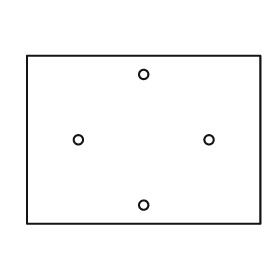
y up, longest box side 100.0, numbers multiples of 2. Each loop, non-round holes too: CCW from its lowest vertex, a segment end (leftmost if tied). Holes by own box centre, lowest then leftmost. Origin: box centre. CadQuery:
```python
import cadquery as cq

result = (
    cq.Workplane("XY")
    .moveTo(-50.0, -36.0)
    .lineTo(50.0, -36.0)
    .lineTo(50.0, 36.0)
    .lineTo(-50.0, 36.0)
    .close()
    .moveTo(0.0, -28.0)
    .circle(2.0)
    .moveTo(-28.0, 0.0)
    .circle(2.0)
    .moveTo(28.0, 0.0)
    .circle(2.0)
    .moveTo(0.0, 28.0)
    .circle(2.0)
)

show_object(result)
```